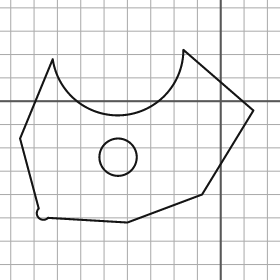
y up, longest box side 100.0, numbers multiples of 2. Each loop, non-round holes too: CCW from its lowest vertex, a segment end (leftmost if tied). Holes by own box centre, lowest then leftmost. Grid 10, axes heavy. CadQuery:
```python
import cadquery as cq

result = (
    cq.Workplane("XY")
    .moveTo(-40.0, -52.0)
    .lineTo(-8.0, -40.0)
    .lineTo(14.0, -4.0)
    .lineTo(-16.0, 22.0)
    .threePointArc((-42.0, -6.0), (-72.0, 18.0))
    .lineTo(-86.0, -16.0)
    .lineTo(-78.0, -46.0)
    .threePointArc((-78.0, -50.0), (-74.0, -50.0))
    .close()
    .moveTo(-44.0, -24.0)
    .circle(8.0)
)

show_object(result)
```